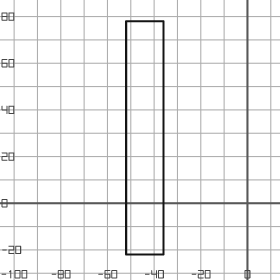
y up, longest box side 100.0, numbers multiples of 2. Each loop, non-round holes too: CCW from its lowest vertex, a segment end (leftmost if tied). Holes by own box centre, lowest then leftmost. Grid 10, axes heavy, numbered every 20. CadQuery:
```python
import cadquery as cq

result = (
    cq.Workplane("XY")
    .moveTo(-52.0, -22.0)
    .lineTo(-36.0, -22.0)
    .lineTo(-36.0, 78.0)
    .lineTo(-52.0, 78.0)
    .close()
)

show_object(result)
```